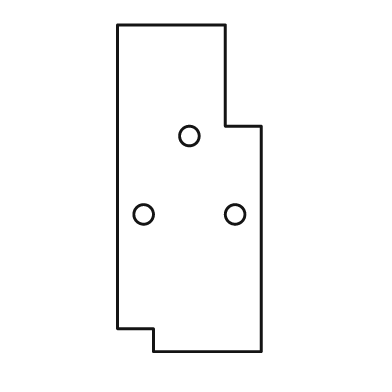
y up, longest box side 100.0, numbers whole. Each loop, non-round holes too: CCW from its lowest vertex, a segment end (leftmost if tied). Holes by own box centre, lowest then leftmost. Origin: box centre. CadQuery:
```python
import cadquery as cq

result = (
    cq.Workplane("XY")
    .moveTo(-11.0, -50.0)
    .lineTo(22.0, -50.0)
    .lineTo(22.0, 19.0)
    .lineTo(11.0, 19.0)
    .lineTo(11.0, 50.0)
    .lineTo(-22.0, 50.0)
    .lineTo(-22.0, -43.0)
    .lineTo(-11.0, -43.0)
    .close()
    .moveTo(-14.0, -8.0)
    .circle(3.0)
    .moveTo(14.0, -8.0)
    .circle(3.0)
    .moveTo(0.0, 16.0)
    .circle(3.0)
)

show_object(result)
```